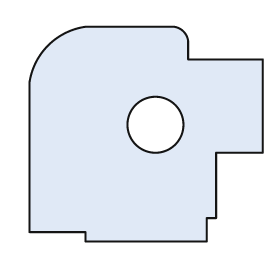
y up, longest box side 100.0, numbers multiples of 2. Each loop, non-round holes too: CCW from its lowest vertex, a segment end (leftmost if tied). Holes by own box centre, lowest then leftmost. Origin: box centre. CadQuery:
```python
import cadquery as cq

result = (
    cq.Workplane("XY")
    .moveTo(-26.0, -46.0)
    .lineTo(26.0, -46.0)
    .lineTo(26.0, -36.0)
    .lineTo(30.0, -36.0)
    .lineTo(30.0, -8.0)
    .lineTo(50.0, -8.0)
    .lineTo(50.0, 32.0)
    .lineTo(18.0, 32.0)
    .lineTo(18.0, 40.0)
    .threePointArc((16.0, 44.0), (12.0, 46.0))
    .lineTo(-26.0, 46.0)
    .threePointArc((-42.0, 38.0), (-50.0, 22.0))
    .lineTo(-50.0, -42.0)
    .lineTo(-26.0, -42.0)
    .close()
    .moveTo(4.0, 4.0)
    .circle(12.0)
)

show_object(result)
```